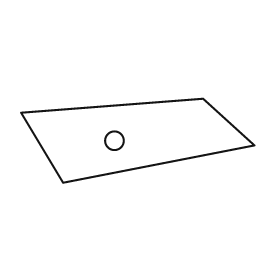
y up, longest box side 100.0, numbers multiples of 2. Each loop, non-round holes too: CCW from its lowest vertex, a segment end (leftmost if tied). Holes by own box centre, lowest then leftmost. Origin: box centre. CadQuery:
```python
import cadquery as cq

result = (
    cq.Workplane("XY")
    .moveTo(-32.0, -18.0)
    .lineTo(50.0, -2.0)
    .lineTo(28.0, 18.0)
    .lineTo(-50.0, 12.0)
    .close()
    .moveTo(-10.0, 0.0)
    .circle(4.0)
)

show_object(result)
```